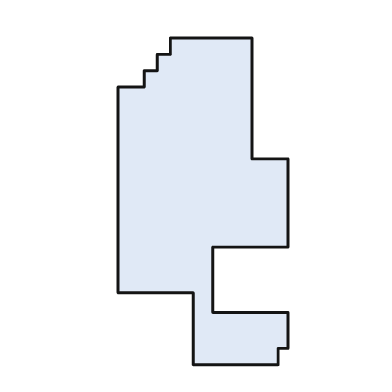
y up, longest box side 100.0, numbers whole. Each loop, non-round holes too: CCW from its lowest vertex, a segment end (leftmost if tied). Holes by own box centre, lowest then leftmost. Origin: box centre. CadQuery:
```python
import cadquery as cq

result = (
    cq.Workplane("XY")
    .moveTo(-3.0, -50.0)
    .lineTo(23.0, -50.0)
    .lineTo(23.0, -45.0)
    .lineTo(26.0, -45.0)
    .lineTo(26.0, -34.0)
    .lineTo(3.0, -34.0)
    .lineTo(3.0, -14.0)
    .lineTo(26.0, -14.0)
    .lineTo(26.0, 13.0)
    .lineTo(15.0, 13.0)
    .lineTo(15.0, 50.0)
    .lineTo(-10.0, 50.0)
    .lineTo(-10.0, 45.0)
    .lineTo(-14.0, 45.0)
    .lineTo(-14.0, 40.0)
    .lineTo(-18.0, 40.0)
    .lineTo(-18.0, 35.0)
    .lineTo(-26.0, 35.0)
    .lineTo(-26.0, -28.0)
    .lineTo(-3.0, -28.0)
    .close()
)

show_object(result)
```